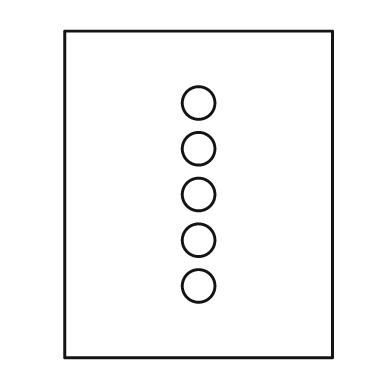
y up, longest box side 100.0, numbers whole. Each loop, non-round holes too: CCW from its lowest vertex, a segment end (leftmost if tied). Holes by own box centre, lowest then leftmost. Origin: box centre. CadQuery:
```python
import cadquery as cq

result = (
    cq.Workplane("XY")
    .moveTo(-41.0, -50.0)
    .lineTo(41.0, -50.0)
    .lineTo(41.0, 50.0)
    .lineTo(-41.0, 50.0)
    .close()
    .moveTo(0.0, -28.0)
    .circle(5.0)
    .moveTo(0.0, -14.0)
    .circle(5.0)
    .moveTo(0.0, 0.0)
    .circle(5.0)
    .moveTo(0.0, 14.0)
    .circle(5.0)
    .moveTo(0.0, 28.0)
    .circle(5.0)
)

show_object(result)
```